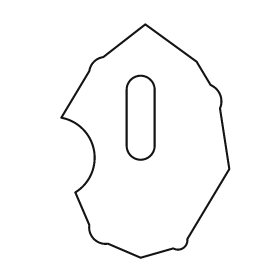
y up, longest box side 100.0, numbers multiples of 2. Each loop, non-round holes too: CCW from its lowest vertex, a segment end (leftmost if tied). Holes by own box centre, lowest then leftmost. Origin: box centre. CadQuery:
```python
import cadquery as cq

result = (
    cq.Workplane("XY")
    .moveTo(-2.0, -50.0)
    .lineTo(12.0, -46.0)
    .threePointArc((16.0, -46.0), (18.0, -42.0))
    .lineTo(36.0, -12.0)
    .lineTo(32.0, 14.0)
    .threePointArc((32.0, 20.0), (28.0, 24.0))
    .lineTo(22.0, 34.0)
    .lineTo(0.0, 50.0)
    .lineTo(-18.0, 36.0)
    .threePointArc((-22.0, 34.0), (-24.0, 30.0))
    .lineTo(-36.0, 10.0)
    .threePointArc((-22.0, -4.0), (-30.0, -22.0))
    .lineTo(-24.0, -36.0)
    .threePointArc((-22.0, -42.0), (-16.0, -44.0))
    .close()
    .moveTo(-8.0, -2.0)
    .threePointArc((-2.0, -8.0), (4.0, -2.0))
    .lineTo(4.0, 22.0)
    .threePointArc((-2.0, 28.0), (-8.0, 22.0))
    .close()
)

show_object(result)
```